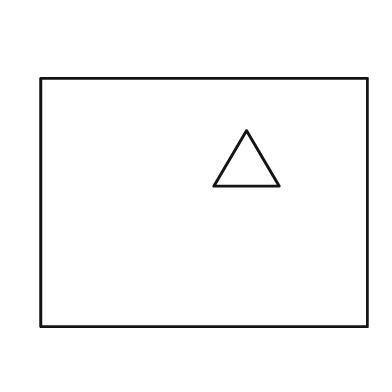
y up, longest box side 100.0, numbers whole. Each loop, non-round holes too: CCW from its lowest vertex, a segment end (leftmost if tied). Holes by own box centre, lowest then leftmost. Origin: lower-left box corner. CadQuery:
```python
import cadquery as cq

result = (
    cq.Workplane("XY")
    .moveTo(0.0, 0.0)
    .lineTo(100.0, 0.0)
    .lineTo(100.0, 76.0)
    .lineTo(0.0, 76.0)
    .close()
    .moveTo(53.0, 43.0)
    .lineTo(73.0, 43.0)
    .lineTo(63.0, 60.0)
    .close()
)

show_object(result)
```